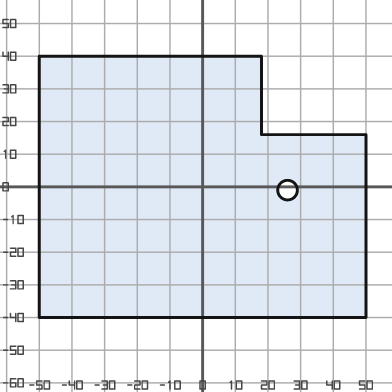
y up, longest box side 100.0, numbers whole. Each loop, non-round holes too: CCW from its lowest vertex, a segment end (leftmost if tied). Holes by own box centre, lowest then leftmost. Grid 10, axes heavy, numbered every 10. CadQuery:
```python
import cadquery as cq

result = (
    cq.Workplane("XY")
    .moveTo(-50.0, -40.0)
    .lineTo(50.0, -40.0)
    .lineTo(50.0, 16.0)
    .lineTo(18.0, 16.0)
    .lineTo(18.0, 40.0)
    .lineTo(-50.0, 40.0)
    .close()
    .moveTo(26.0, -1.0)
    .circle(3.0)
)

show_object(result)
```